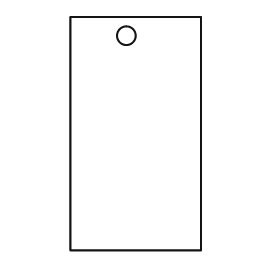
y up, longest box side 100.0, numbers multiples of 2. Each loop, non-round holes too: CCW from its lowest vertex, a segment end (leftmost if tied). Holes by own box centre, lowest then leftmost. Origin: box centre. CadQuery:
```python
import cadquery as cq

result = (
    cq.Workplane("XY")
    .moveTo(-28.0, -50.0)
    .lineTo(28.0, -50.0)
    .lineTo(28.0, 50.0)
    .lineTo(-28.0, 50.0)
    .close()
    .moveTo(-4.0, 42.0)
    .circle(4.0)
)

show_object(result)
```